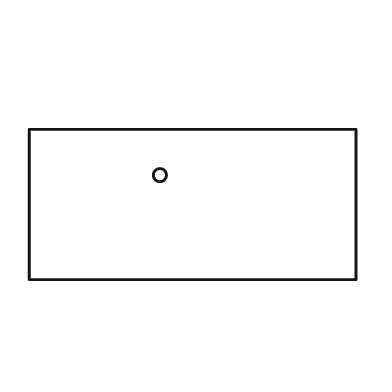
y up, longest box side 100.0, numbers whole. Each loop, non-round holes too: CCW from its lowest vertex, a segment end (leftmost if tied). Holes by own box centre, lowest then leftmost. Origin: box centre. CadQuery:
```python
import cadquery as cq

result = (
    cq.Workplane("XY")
    .moveTo(-50.0, -23.0)
    .lineTo(50.0, -23.0)
    .lineTo(50.0, 23.0)
    .lineTo(-50.0, 23.0)
    .close()
    .moveTo(-10.0, 9.0)
    .circle(2.0)
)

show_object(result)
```